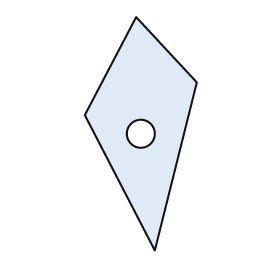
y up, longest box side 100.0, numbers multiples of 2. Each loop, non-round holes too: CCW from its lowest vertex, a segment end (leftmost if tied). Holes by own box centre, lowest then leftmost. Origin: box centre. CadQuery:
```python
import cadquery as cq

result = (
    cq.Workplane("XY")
    .moveTo(6.0, -50.0)
    .lineTo(24.0, 22.0)
    .lineTo(-2.0, 50.0)
    .lineTo(-24.0, 8.0)
    .close()
    .moveTo(0.0, 0.0)
    .circle(6.0)
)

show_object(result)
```